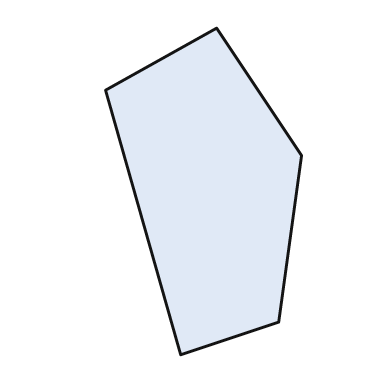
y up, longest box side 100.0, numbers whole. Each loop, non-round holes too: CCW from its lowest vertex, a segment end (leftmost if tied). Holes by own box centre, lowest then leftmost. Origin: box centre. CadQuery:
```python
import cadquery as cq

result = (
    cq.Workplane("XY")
    .moveTo(-7.0, -50.0)
    .lineTo(23.0, -40.0)
    .lineTo(30.0, 11.0)
    .lineTo(4.0, 50.0)
    .lineTo(-30.0, 31.0)
    .close()
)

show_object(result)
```